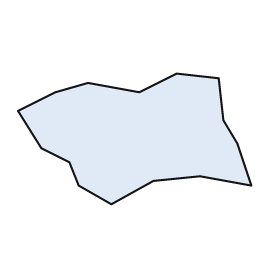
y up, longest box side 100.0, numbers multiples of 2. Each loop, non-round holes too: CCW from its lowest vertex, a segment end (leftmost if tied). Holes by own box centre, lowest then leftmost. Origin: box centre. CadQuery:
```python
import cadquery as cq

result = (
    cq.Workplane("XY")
    .moveTo(-10.0, -28.0)
    .lineTo(8.0, -18.0)
    .lineTo(28.0, -16.0)
    .lineTo(50.0, -20.0)
    .lineTo(44.0, -2.0)
    .lineTo(38.0, 8.0)
    .lineTo(36.0, 26.0)
    .lineTo(18.0, 28.0)
    .lineTo(2.0, 20.0)
    .lineTo(-20.0, 24.0)
    .lineTo(-34.0, 20.0)
    .lineTo(-50.0, 12.0)
    .lineTo(-40.0, -4.0)
    .lineTo(-28.0, -10.0)
    .lineTo(-24.0, -20.0)
    .close()
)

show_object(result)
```